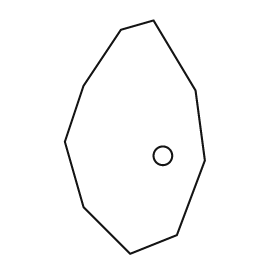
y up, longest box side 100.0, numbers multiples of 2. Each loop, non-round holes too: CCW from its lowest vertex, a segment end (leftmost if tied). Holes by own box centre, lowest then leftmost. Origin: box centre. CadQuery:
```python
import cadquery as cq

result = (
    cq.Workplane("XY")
    .moveTo(-2.0, -50.0)
    .lineTo(18.0, -42.0)
    .lineTo(30.0, -10.0)
    .lineTo(26.0, 20.0)
    .lineTo(8.0, 50.0)
    .lineTo(-6.0, 46.0)
    .lineTo(-22.0, 22.0)
    .lineTo(-30.0, -2.0)
    .lineTo(-22.0, -30.0)
    .close()
    .moveTo(12.0, -8.0)
    .circle(4.0)
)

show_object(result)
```